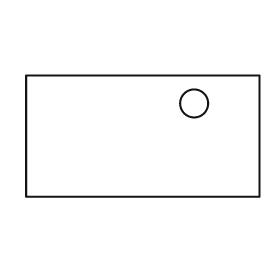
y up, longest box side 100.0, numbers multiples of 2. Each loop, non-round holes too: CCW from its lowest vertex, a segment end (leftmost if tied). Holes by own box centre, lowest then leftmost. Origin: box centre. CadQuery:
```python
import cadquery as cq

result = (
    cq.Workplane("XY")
    .moveTo(-50.0, -26.0)
    .lineTo(50.0, -26.0)
    .lineTo(50.0, 26.0)
    .lineTo(-50.0, 26.0)
    .close()
    .moveTo(22.0, 14.0)
    .circle(6.0)
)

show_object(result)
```